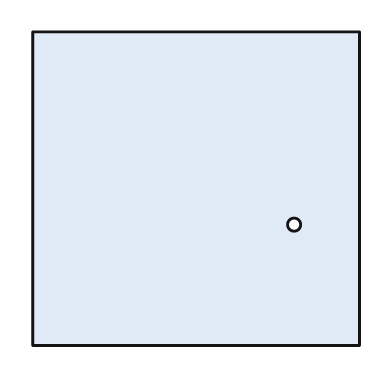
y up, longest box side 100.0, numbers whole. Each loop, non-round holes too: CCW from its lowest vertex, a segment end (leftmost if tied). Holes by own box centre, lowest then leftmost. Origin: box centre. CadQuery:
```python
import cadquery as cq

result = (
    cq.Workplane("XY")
    .moveTo(-50.0, -48.0)
    .lineTo(50.0, -48.0)
    .lineTo(50.0, 48.0)
    .lineTo(-50.0, 48.0)
    .close()
    .moveTo(30.0, -11.0)
    .circle(2.0)
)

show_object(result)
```